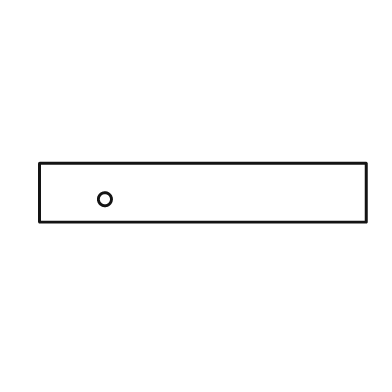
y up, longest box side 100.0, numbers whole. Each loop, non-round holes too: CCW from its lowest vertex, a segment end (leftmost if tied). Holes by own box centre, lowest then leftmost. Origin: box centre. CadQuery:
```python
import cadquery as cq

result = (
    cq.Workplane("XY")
    .moveTo(-50.0, -9.0)
    .lineTo(50.0, -9.0)
    .lineTo(50.0, 9.0)
    .lineTo(-50.0, 9.0)
    .close()
    .moveTo(-30.0, -2.0)
    .circle(2.0)
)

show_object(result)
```